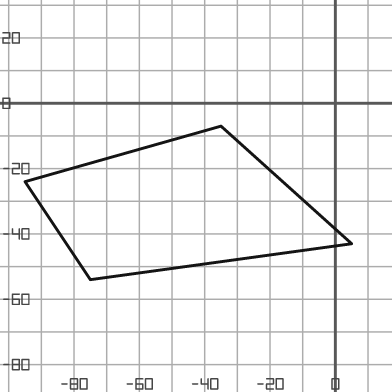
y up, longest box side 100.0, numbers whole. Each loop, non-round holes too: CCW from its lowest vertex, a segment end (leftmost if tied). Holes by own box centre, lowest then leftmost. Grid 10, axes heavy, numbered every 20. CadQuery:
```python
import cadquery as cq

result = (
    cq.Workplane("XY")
    .moveTo(-75.0, -54.0)
    .lineTo(5.0, -43.0)
    .lineTo(-35.0, -7.0)
    .lineTo(-95.0, -24.0)
    .close()
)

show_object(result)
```